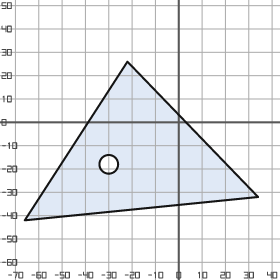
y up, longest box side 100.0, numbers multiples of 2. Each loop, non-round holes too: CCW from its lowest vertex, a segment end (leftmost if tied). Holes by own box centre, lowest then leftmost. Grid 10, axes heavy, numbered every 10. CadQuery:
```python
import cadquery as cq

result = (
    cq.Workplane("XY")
    .moveTo(-66.0, -42.0)
    .lineTo(34.0, -32.0)
    .lineTo(-22.0, 26.0)
    .close()
    .moveTo(-30.0, -18.0)
    .circle(4.0)
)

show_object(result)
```